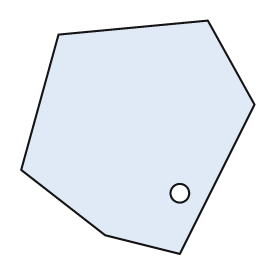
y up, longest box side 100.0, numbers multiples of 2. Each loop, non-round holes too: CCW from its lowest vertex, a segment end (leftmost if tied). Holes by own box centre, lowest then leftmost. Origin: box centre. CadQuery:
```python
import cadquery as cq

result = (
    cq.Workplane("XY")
    .moveTo(18.0, -50.0)
    .lineTo(50.0, 14.0)
    .lineTo(30.0, 50.0)
    .lineTo(-34.0, 44.0)
    .lineTo(-50.0, -14.0)
    .lineTo(-14.0, -42.0)
    .close()
    .moveTo(18.0, -24.0)
    .circle(4.0)
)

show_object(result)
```